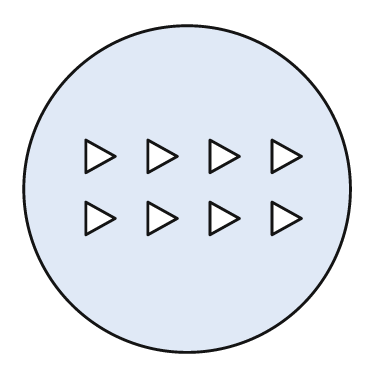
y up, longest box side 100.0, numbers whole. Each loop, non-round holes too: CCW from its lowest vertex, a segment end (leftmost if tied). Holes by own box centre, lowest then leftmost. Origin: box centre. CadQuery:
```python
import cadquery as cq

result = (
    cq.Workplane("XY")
    .moveTo(0.0, 0.0)
    .circle(50.0)
    .moveTo(-31.0, -14.0)
    .lineTo(-22.0, -9.0)
    .lineTo(-31.0, -4.0)
    .close()
    .moveTo(-12.0, -14.0)
    .lineTo(-3.0, -9.0)
    .lineTo(-12.0, -4.0)
    .close()
    .moveTo(7.0, -14.0)
    .lineTo(16.0, -9.0)
    .lineTo(7.0, -4.0)
    .close()
    .moveTo(26.0, -14.0)
    .lineTo(35.0, -9.0)
    .lineTo(26.0, -4.0)
    .close()
    .moveTo(-31.0, 5.0)
    .lineTo(-22.0, 10.0)
    .lineTo(-31.0, 15.0)
    .close()
    .moveTo(-12.0, 5.0)
    .lineTo(-3.0, 10.0)
    .lineTo(-12.0, 15.0)
    .close()
    .moveTo(7.0, 5.0)
    .lineTo(16.0, 10.0)
    .lineTo(7.0, 15.0)
    .close()
    .moveTo(26.0, 5.0)
    .lineTo(35.0, 10.0)
    .lineTo(26.0, 15.0)
    .close()
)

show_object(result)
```